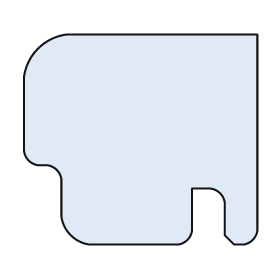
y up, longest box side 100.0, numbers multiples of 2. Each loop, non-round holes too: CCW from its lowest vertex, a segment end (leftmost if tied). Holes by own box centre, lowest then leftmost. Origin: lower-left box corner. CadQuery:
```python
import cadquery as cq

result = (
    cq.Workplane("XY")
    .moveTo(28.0, 0.0)
    .lineTo(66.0, 0.0)
    .threePointArc((70.0, 2.0), (72.0, 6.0))
    .lineTo(72.0, 24.0)
    .lineTo(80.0, 24.0)
    .threePointArc((84.0, 22.0), (86.0, 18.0))
    .lineTo(86.0, 4.0)
    .lineTo(90.0, 0.0)
    .lineTo(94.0, 0.0)
    .threePointArc((98.0, 2.0), (100.0, 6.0))
    .lineTo(100.0, 90.0)
    .lineTo(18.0, 90.0)
    .threePointArc((6.0, 84.0), (0.0, 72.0))
    .lineTo(0.0, 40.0)
    .threePointArc((2.0, 36.0), (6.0, 34.0))
    .lineTo(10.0, 34.0)
    .threePointArc((14.0, 32.0), (16.0, 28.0))
    .lineTo(16.0, 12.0)
    .threePointArc((20.0, 4.0), (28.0, 0.0))
    .close()
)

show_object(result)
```